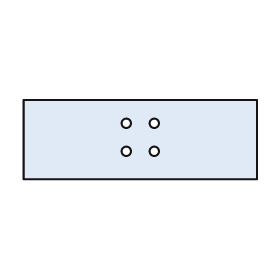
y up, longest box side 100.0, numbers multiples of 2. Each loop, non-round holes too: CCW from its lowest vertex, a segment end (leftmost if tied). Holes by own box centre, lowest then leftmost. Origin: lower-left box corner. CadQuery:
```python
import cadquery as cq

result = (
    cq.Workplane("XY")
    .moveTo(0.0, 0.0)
    .lineTo(100.0, 0.0)
    .lineTo(100.0, 34.0)
    .lineTo(0.0, 34.0)
    .close()
    .moveTo(44.0, 12.0)
    .circle(2.0)
    .moveTo(56.0, 12.0)
    .circle(2.0)
    .moveTo(44.0, 24.0)
    .circle(2.0)
    .moveTo(56.0, 24.0)
    .circle(2.0)
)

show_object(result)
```